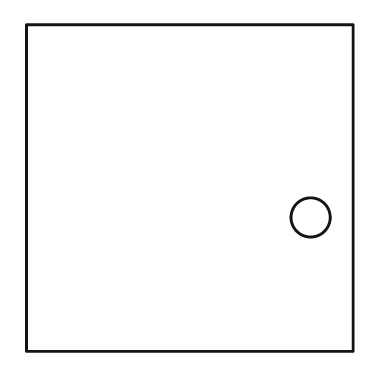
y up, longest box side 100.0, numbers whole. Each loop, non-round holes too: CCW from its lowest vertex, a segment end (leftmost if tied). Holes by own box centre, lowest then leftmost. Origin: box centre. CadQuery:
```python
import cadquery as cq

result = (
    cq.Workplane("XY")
    .moveTo(-50.0, -50.0)
    .lineTo(50.0, -50.0)
    .lineTo(50.0, 50.0)
    .lineTo(-50.0, 50.0)
    .close()
    .moveTo(37.0, -9.0)
    .circle(6.0)
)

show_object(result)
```